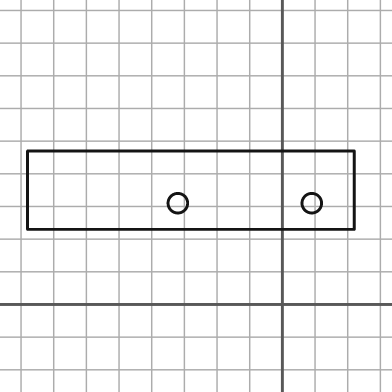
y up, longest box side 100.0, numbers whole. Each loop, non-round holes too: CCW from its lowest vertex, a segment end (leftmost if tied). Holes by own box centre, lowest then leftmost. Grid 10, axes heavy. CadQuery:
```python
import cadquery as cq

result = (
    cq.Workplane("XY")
    .moveTo(-78.0, 23.0)
    .lineTo(22.0, 23.0)
    .lineTo(22.0, 47.0)
    .lineTo(-78.0, 47.0)
    .close()
    .moveTo(-32.0, 31.0)
    .circle(3.0)
    .moveTo(9.0, 31.0)
    .circle(3.0)
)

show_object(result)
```